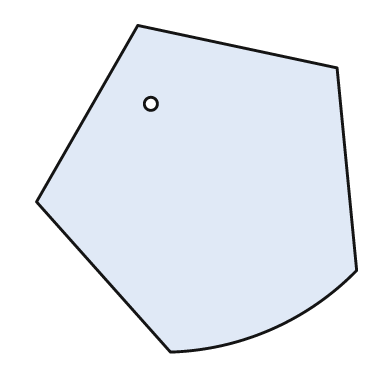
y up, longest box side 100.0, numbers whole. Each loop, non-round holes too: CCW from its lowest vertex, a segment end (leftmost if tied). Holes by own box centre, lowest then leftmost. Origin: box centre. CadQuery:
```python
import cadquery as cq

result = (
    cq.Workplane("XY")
    .moveTo(-8.0, -50.0)
    .threePointArc((23.0, -43.0), (49.0, -25.0))
    .lineTo(43.0, 37.0)
    .lineTo(-18.0, 50.0)
    .lineTo(-49.0, -4.0)
    .close()
    .moveTo(-14.0, 26.0)
    .circle(2.0)
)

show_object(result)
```